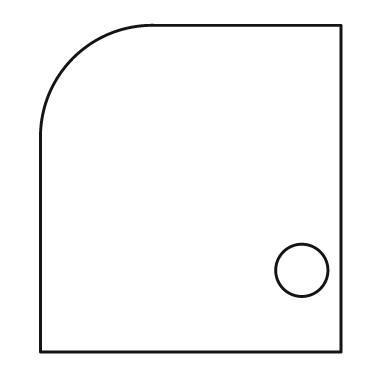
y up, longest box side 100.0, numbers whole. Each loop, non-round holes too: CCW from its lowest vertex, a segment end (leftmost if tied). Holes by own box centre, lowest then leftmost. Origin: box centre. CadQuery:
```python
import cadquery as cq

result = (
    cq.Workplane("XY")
    .moveTo(-46.0, -50.0)
    .lineTo(46.0, -50.0)
    .lineTo(46.0, 50.0)
    .lineTo(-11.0, 50.0)
    .threePointArc((-36.0, 40.0), (-46.0, 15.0))
    .close()
    .moveTo(34.0, -25.0)
    .circle(8.0)
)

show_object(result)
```